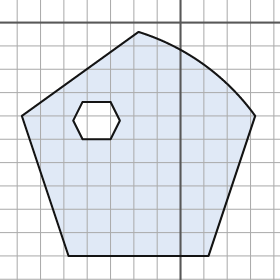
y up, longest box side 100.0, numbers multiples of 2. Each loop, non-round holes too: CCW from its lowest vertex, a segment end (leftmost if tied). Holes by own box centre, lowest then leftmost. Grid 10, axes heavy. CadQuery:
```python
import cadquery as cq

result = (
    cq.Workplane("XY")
    .moveTo(-48.0, -100.0)
    .lineTo(12.0, -100.0)
    .lineTo(32.0, -40.0)
    .threePointArc((10.0, -18.0), (-18.0, -4.0))
    .lineTo(-68.0, -40.0)
    .close()
    .moveTo(-42.0, -50.0)
    .lineTo(-30.0, -50.0)
    .lineTo(-26.0, -42.0)
    .lineTo(-30.0, -34.0)
    .lineTo(-42.0, -34.0)
    .lineTo(-46.0, -42.0)
    .close()
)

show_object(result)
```